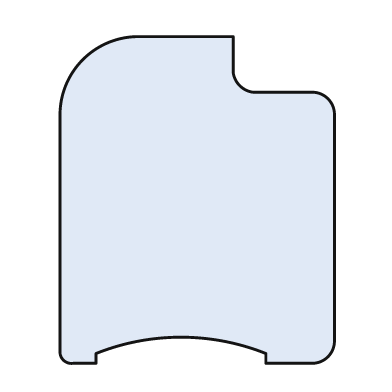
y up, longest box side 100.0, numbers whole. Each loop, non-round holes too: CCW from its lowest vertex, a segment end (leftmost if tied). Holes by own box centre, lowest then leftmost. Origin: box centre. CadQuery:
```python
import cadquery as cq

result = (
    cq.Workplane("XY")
    .moveTo(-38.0, -50.0)
    .lineTo(-31.0, -50.0)
    .lineTo(-31.0, -47.0)
    .threePointArc((-5.0, -42.0), (21.0, -47.0))
    .lineTo(21.0, -50.0)
    .lineTo(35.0, -50.0)
    .threePointArc((40.0, -48.0), (42.0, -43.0))
    .lineTo(42.0, 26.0)
    .threePointArc((40.0, 31.0), (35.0, 33.0))
    .lineTo(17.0, 33.0)
    .threePointArc((13.0, 35.0), (11.0, 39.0))
    .lineTo(11.0, 50.0)
    .lineTo(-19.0, 50.0)
    .threePointArc((-35.0, 43.0), (-42.0, 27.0))
    .lineTo(-42.0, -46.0)
    .threePointArc((-41.0, -49.0), (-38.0, -50.0))
    .close()
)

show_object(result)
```